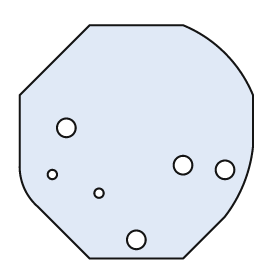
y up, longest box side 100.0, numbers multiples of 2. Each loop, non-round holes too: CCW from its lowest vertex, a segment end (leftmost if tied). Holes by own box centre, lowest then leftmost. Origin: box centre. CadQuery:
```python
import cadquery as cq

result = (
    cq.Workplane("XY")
    .moveTo(-20.0, -50.0)
    .lineTo(20.0, -50.0)
    .lineTo(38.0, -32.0)
    .threePointArc((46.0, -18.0), (50.0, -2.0))
    .lineTo(50.0, 20.0)
    .threePointArc((38.0, 38.0), (20.0, 50.0))
    .lineTo(-20.0, 50.0)
    .lineTo(-50.0, 20.0)
    .lineTo(-50.0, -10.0)
    .threePointArc((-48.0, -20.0), (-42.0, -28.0))
    .close()
    .moveTo(0.0, -42.0)
    .circle(4.0)
    .moveTo(-16.0, -22.0)
    .circle(2.0)
    .moveTo(-36.0, -14.0)
    .circle(2.0)
    .moveTo(38.0, -12.0)
    .circle(4.0)
    .moveTo(20.0, -10.0)
    .circle(4.0)
    .moveTo(-30.0, 6.0)
    .circle(4.0)
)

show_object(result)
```